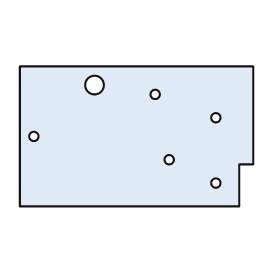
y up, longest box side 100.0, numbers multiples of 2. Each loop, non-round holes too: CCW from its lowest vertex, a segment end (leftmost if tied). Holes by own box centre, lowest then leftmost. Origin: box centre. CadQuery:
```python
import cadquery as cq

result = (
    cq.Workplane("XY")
    .moveTo(-50.0, -30.0)
    .lineTo(44.0, -30.0)
    .lineTo(44.0, -12.0)
    .lineTo(50.0, -12.0)
    .lineTo(50.0, 30.0)
    .lineTo(-50.0, 30.0)
    .close()
    .moveTo(34.0, -20.0)
    .circle(2.0)
    .moveTo(14.0, -10.0)
    .circle(2.0)
    .moveTo(-44.0, 0.0)
    .circle(2.0)
    .moveTo(34.0, 8.0)
    .circle(2.0)
    .moveTo(8.0, 18.0)
    .circle(2.0)
    .moveTo(-18.0, 22.0)
    .circle(4.0)
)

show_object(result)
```